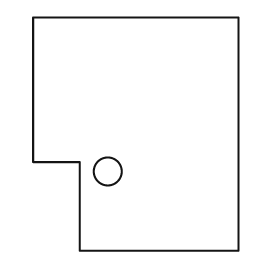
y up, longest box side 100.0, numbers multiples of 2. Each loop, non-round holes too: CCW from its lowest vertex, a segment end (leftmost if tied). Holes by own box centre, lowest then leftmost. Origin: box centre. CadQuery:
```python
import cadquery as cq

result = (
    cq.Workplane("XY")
    .moveTo(-24.0, -50.0)
    .lineTo(44.0, -50.0)
    .lineTo(44.0, 50.0)
    .lineTo(-44.0, 50.0)
    .lineTo(-44.0, -12.0)
    .lineTo(-24.0, -12.0)
    .close()
    .moveTo(-12.0, -16.0)
    .circle(6.0)
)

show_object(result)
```